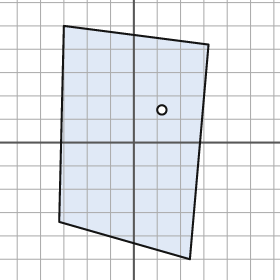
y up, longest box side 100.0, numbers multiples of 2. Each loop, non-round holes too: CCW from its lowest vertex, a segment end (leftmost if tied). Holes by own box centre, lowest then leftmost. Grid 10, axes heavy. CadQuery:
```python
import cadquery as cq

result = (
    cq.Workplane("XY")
    .moveTo(24.0, -50.0)
    .lineTo(32.0, 42.0)
    .lineTo(-30.0, 50.0)
    .lineTo(-32.0, -34.0)
    .close()
    .moveTo(12.0, 14.0)
    .circle(2.0)
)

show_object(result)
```